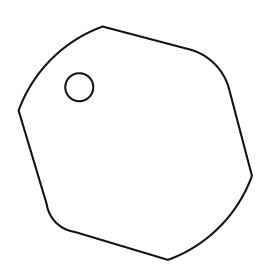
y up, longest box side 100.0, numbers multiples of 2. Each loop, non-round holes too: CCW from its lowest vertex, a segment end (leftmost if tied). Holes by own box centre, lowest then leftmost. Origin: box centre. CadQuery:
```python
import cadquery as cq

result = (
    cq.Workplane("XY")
    .moveTo(14.0, -50.0)
    .threePointArc((36.0, -36.0), (50.0, -14.0))
    .lineTo(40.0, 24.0)
    .threePointArc((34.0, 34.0), (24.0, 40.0))
    .lineTo(-14.0, 50.0)
    .threePointArc((-36.0, 36.0), (-50.0, 14.0))
    .lineTo(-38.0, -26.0)
    .threePointArc((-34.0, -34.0), (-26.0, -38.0))
    .close()
    .moveTo(-24.0, 24.0)
    .circle(6.0)
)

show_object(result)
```